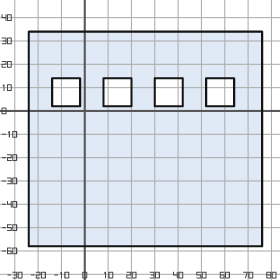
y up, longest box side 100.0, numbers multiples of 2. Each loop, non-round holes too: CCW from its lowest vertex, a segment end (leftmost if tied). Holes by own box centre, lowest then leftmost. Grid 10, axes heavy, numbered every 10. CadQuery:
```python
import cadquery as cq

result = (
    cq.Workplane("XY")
    .moveTo(-24.0, -58.0)
    .lineTo(76.0, -58.0)
    .lineTo(76.0, 34.0)
    .lineTo(-24.0, 34.0)
    .close()
    .moveTo(-14.0, 2.0)
    .lineTo(-2.0, 2.0)
    .lineTo(-2.0, 14.0)
    .lineTo(-14.0, 14.0)
    .close()
    .moveTo(8.0, 2.0)
    .lineTo(20.0, 2.0)
    .lineTo(20.0, 14.0)
    .lineTo(8.0, 14.0)
    .close()
    .moveTo(30.0, 2.0)
    .lineTo(42.0, 2.0)
    .lineTo(42.0, 14.0)
    .lineTo(30.0, 14.0)
    .close()
    .moveTo(52.0, 2.0)
    .lineTo(64.0, 2.0)
    .lineTo(64.0, 14.0)
    .lineTo(52.0, 14.0)
    .close()
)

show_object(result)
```